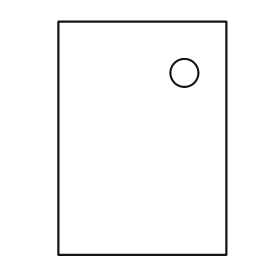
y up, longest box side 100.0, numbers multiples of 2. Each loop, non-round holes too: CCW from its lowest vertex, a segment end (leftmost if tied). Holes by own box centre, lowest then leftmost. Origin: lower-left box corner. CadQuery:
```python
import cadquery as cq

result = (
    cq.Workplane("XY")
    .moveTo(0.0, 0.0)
    .lineTo(72.0, 0.0)
    .lineTo(72.0, 100.0)
    .lineTo(0.0, 100.0)
    .close()
    .moveTo(54.0, 78.0)
    .circle(6.0)
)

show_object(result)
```